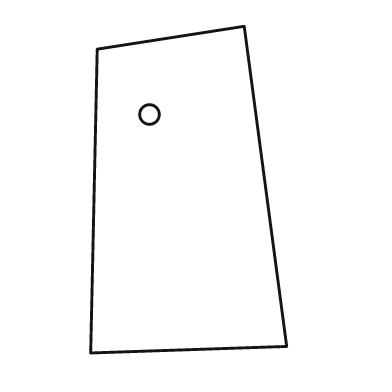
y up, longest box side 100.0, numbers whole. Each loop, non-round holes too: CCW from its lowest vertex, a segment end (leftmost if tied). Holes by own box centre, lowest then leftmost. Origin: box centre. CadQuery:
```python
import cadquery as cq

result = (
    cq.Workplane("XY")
    .moveTo(-30.0, -50.0)
    .lineTo(30.0, -48.0)
    .lineTo(17.0, 50.0)
    .lineTo(-28.0, 43.0)
    .close()
    .moveTo(-12.0, 23.0)
    .circle(3.0)
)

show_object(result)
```